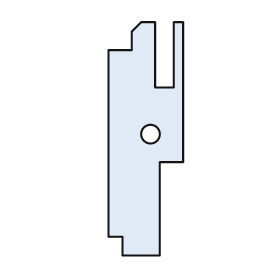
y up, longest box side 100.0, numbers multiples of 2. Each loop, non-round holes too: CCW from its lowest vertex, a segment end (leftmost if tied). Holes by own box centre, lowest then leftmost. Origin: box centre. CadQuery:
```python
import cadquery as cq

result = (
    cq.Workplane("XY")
    .moveTo(-10.0, -50.0)
    .lineTo(6.0, -50.0)
    .lineTo(6.0, -10.0)
    .lineTo(16.0, -10.0)
    .lineTo(16.0, 50.0)
    .lineTo(12.0, 50.0)
    .lineTo(12.0, 22.0)
    .lineTo(4.0, 22.0)
    .lineTo(4.0, 50.0)
    .lineTo(-2.0, 50.0)
    .lineTo(-6.0, 46.0)
    .lineTo(-6.0, 38.0)
    .lineTo(-16.0, 38.0)
    .lineTo(-16.0, -42.0)
    .lineTo(-10.0, -42.0)
    .close()
    .moveTo(2.0, 2.0)
    .circle(4.0)
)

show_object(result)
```